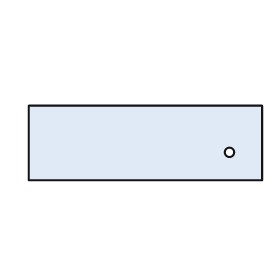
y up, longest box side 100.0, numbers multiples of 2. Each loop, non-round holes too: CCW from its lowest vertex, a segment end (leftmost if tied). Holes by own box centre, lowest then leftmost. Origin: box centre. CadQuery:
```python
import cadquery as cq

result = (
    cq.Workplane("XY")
    .moveTo(-50.0, -16.0)
    .lineTo(50.0, -16.0)
    .lineTo(50.0, 16.0)
    .lineTo(-50.0, 16.0)
    .close()
    .moveTo(36.0, -4.0)
    .circle(2.0)
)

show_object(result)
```